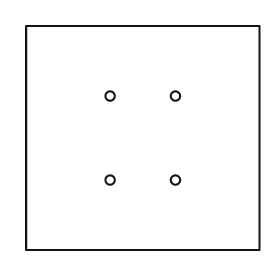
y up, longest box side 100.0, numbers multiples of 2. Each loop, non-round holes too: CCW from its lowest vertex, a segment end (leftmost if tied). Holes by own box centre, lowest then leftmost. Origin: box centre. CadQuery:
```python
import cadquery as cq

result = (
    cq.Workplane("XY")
    .moveTo(-50.0, -48.0)
    .lineTo(50.0, -48.0)
    .lineTo(50.0, 48.0)
    .lineTo(-50.0, 48.0)
    .close()
    .moveTo(-14.0, -18.0)
    .circle(2.0)
    .moveTo(14.0, -18.0)
    .circle(2.0)
    .moveTo(-14.0, 18.0)
    .circle(2.0)
    .moveTo(14.0, 18.0)
    .circle(2.0)
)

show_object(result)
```